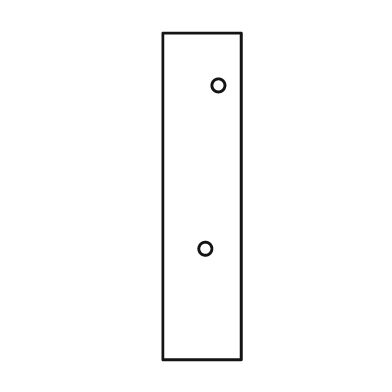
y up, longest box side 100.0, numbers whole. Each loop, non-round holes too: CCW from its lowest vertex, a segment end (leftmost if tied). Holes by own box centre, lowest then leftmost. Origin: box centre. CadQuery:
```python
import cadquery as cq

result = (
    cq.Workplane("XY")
    .moveTo(-12.0, -50.0)
    .lineTo(12.0, -50.0)
    .lineTo(12.0, 50.0)
    .lineTo(-12.0, 50.0)
    .close()
    .moveTo(1.0, -16.0)
    .circle(2.0)
    .moveTo(5.0, 34.0)
    .circle(2.0)
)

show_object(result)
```